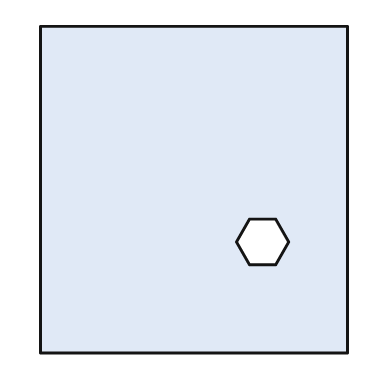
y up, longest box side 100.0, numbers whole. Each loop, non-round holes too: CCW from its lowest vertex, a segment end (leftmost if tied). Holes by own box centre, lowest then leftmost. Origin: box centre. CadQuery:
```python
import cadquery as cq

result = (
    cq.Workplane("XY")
    .moveTo(-47.0, -50.0)
    .lineTo(47.0, -50.0)
    .lineTo(47.0, 50.0)
    .lineTo(-47.0, 50.0)
    .close()
    .moveTo(17.0, -23.0)
    .lineTo(25.0, -23.0)
    .lineTo(29.0, -16.0)
    .lineTo(25.0, -9.0)
    .lineTo(17.0, -9.0)
    .lineTo(13.0, -16.0)
    .close()
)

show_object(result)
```